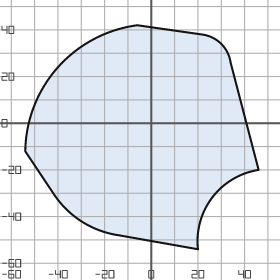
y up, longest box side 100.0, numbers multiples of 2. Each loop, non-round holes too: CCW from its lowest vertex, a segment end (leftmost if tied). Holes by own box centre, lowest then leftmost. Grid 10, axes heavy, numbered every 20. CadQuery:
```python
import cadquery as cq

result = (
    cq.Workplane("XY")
    .moveTo(20.0, -54.0)
    .threePointArc((26.0, -32.0), (46.0, -20.0))
    .lineTo(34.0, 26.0)
    .threePointArc((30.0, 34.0), (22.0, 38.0))
    .lineTo(-6.0, 42.0)
    .threePointArc((-40.0, 24.0), (-54.0, -12.0))
    .lineTo(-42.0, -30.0)
    .threePointArc((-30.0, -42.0), (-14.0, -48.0))
    .close()
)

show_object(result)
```